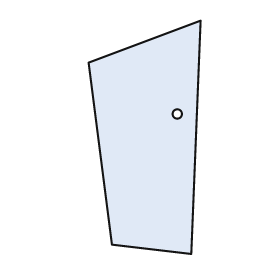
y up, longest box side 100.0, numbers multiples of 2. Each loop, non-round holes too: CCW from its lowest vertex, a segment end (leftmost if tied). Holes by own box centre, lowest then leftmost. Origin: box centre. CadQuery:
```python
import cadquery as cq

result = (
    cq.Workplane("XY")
    .moveTo(20.0, -50.0)
    .lineTo(24.0, 50.0)
    .lineTo(-24.0, 32.0)
    .lineTo(-14.0, -46.0)
    .close()
    .moveTo(14.0, 10.0)
    .circle(2.0)
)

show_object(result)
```